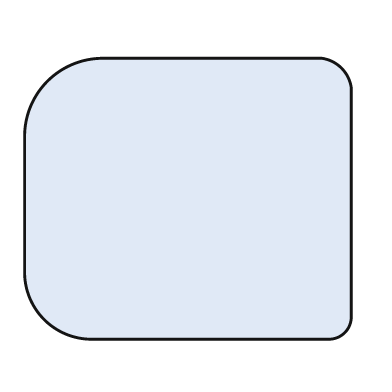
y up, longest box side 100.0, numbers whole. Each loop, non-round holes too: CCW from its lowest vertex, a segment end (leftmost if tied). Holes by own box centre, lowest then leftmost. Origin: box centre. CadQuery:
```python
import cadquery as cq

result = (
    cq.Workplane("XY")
    .moveTo(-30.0, -43.0)
    .lineTo(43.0, -43.0)
    .threePointArc((48.0, -41.0), (50.0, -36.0))
    .lineTo(50.0, 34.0)
    .threePointArc((47.0, 40.0), (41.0, 43.0))
    .lineTo(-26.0, 43.0)
    .threePointArc((-43.0, 36.0), (-50.0, 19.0))
    .lineTo(-50.0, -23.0)
    .threePointArc((-44.0, -37.0), (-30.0, -43.0))
    .close()
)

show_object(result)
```